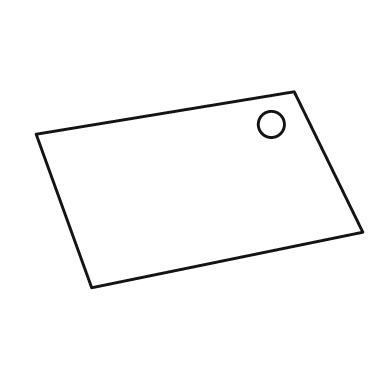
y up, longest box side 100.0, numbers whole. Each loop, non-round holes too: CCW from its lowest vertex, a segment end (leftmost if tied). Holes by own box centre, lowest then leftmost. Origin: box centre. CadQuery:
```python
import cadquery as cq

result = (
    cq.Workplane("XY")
    .moveTo(-33.0, -30.0)
    .lineTo(50.0, -13.0)
    .lineTo(29.0, 30.0)
    .lineTo(-50.0, 17.0)
    .close()
    .moveTo(22.0, 20.0)
    .circle(4.0)
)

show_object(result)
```